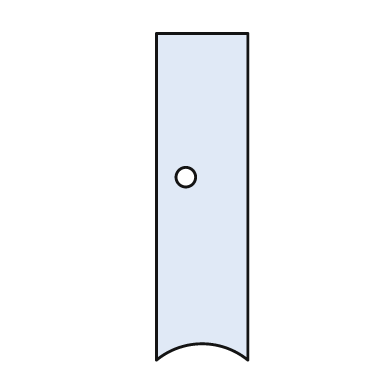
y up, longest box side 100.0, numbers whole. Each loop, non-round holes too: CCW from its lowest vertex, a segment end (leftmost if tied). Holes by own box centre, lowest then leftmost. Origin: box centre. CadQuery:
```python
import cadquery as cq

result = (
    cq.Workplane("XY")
    .moveTo(-14.0, -50.0)
    .threePointArc((0.0, -45.0), (14.0, -50.0))
    .lineTo(14.0, 50.0)
    .lineTo(-14.0, 50.0)
    .close()
    .moveTo(-5.0, 6.0)
    .circle(3.0)
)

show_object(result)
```